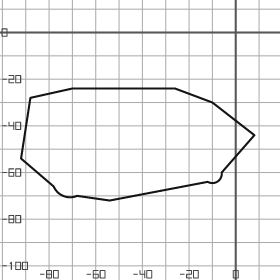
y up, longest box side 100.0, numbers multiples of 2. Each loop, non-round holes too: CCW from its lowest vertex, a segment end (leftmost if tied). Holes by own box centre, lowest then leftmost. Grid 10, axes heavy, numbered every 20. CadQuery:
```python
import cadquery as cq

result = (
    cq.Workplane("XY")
    .moveTo(-54.0, -72.0)
    .lineTo(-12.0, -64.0)
    .threePointArc((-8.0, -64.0), (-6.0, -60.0))
    .lineTo(8.0, -44.0)
    .lineTo(-10.0, -30.0)
    .lineTo(-26.0, -24.0)
    .lineTo(-70.0, -24.0)
    .lineTo(-88.0, -28.0)
    .lineTo(-92.0, -54.0)
    .lineTo(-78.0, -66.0)
    .threePointArc((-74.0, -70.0), (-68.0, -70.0))
    .close()
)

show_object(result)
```